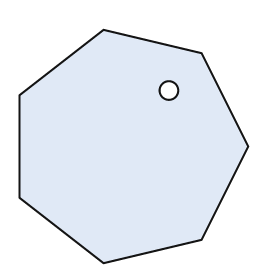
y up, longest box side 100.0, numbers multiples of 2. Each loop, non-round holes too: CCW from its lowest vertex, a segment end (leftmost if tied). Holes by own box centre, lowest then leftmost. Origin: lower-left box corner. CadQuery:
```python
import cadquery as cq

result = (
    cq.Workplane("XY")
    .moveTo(36.0, 0.0)
    .lineTo(78.0, 10.0)
    .lineTo(98.0, 50.0)
    .lineTo(78.0, 90.0)
    .lineTo(36.0, 100.0)
    .lineTo(0.0, 72.0)
    .lineTo(0.0, 28.0)
    .close()
    .moveTo(64.0, 74.0)
    .circle(4.0)
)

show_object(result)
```